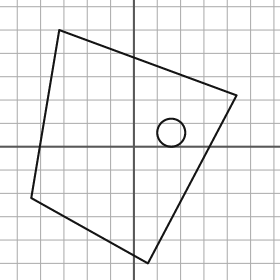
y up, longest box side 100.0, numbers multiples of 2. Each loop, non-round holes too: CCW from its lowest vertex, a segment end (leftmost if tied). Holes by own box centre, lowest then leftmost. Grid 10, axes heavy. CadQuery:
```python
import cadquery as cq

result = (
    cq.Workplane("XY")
    .moveTo(6.0, -50.0)
    .lineTo(44.0, 22.0)
    .lineTo(-32.0, 50.0)
    .lineTo(-44.0, -22.0)
    .close()
    .moveTo(16.0, 6.0)
    .circle(6.0)
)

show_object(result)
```